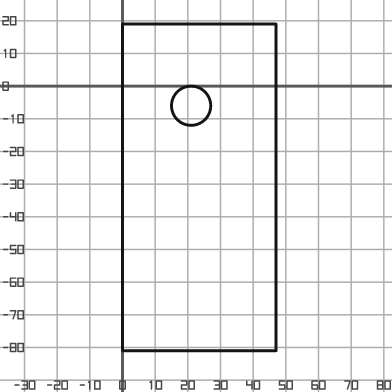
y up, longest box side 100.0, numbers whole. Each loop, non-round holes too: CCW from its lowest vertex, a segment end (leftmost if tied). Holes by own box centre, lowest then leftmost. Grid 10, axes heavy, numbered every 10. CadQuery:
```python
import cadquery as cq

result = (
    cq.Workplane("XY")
    .moveTo(0.0, -81.0)
    .lineTo(47.0, -81.0)
    .lineTo(47.0, 19.0)
    .lineTo(0.0, 19.0)
    .close()
    .moveTo(21.0, -6.0)
    .circle(6.0)
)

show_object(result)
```